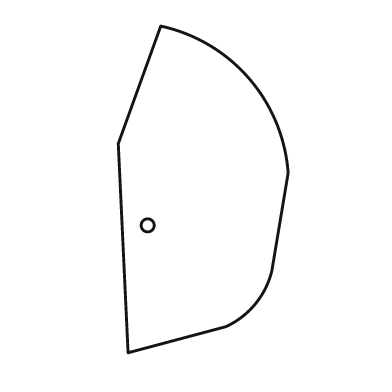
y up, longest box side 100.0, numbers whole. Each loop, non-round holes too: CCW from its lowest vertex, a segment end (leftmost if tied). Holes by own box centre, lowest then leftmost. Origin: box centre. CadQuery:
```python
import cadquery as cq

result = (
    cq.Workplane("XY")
    .moveTo(-23.0, -50.0)
    .lineTo(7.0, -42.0)
    .threePointArc((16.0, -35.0), (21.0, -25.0))
    .lineTo(26.0, 5.0)
    .threePointArc((14.0, 34.0), (-13.0, 50.0))
    .lineTo(-26.0, 14.0)
    .close()
    .moveTo(-17.0, -11.0)
    .circle(2.0)
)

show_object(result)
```